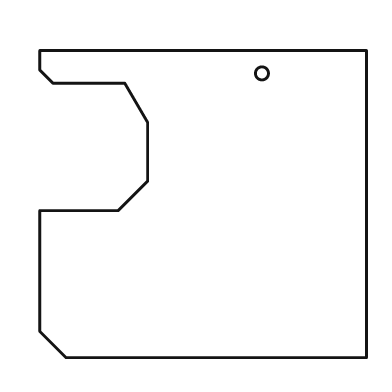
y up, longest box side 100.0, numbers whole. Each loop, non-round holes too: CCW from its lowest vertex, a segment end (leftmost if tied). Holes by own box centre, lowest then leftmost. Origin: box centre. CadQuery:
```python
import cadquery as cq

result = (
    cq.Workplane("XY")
    .moveTo(-42.0, -47.0)
    .lineTo(50.0, -47.0)
    .lineTo(50.0, 47.0)
    .lineTo(-50.0, 47.0)
    .lineTo(-50.0, 41.0)
    .lineTo(-46.0, 37.0)
    .lineTo(-24.0, 37.0)
    .lineTo(-17.0, 25.0)
    .lineTo(-17.0, 7.0)
    .lineTo(-26.0, -2.0)
    .lineTo(-50.0, -2.0)
    .lineTo(-50.0, -39.0)
    .close()
    .moveTo(18.0, 40.0)
    .circle(2.0)
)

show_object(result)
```